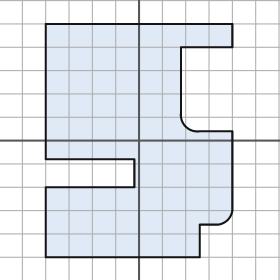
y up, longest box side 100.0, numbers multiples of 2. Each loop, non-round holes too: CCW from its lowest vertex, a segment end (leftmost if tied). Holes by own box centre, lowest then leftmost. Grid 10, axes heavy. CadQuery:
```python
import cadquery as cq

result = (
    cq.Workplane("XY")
    .moveTo(-40.0, -50.0)
    .lineTo(26.0, -50.0)
    .lineTo(26.0, -36.0)
    .lineTo(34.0, -36.0)
    .threePointArc((38.0, -34.0), (40.0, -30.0))
    .lineTo(40.0, 4.0)
    .lineTo(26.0, 4.0)
    .threePointArc((20.0, 6.0), (18.0, 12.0))
    .lineTo(18.0, 40.0)
    .lineTo(40.0, 40.0)
    .lineTo(40.0, 50.0)
    .lineTo(-40.0, 50.0)
    .lineTo(-40.0, -8.0)
    .lineTo(-2.0, -8.0)
    .lineTo(-2.0, -20.0)
    .lineTo(-40.0, -20.0)
    .close()
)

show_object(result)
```